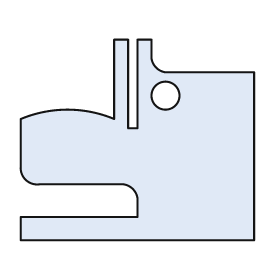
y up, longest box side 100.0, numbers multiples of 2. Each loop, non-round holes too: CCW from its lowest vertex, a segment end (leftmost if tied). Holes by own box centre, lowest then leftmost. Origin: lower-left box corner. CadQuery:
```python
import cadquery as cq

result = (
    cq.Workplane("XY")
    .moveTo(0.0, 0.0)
    .lineTo(100.0, 0.0)
    .lineTo(100.0, 72.0)
    .lineTo(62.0, 72.0)
    .threePointArc((58.0, 74.0), (56.0, 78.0))
    .lineTo(56.0, 86.0)
    .lineTo(50.0, 86.0)
    .lineTo(50.0, 48.0)
    .lineTo(46.0, 48.0)
    .lineTo(46.0, 86.0)
    .lineTo(40.0, 86.0)
    .lineTo(40.0, 52.0)
    .threePointArc((20.0, 56.0), (0.0, 52.0))
    .lineTo(0.0, 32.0)
    .threePointArc((2.0, 26.0), (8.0, 24.0))
    .lineTo(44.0, 24.0)
    .threePointArc((48.0, 22.0), (50.0, 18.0))
    .lineTo(50.0, 10.0)
    .lineTo(0.0, 10.0)
    .close()
    .moveTo(62.0, 62.0)
    .circle(6.0)
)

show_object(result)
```